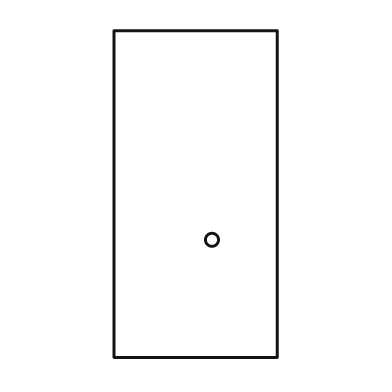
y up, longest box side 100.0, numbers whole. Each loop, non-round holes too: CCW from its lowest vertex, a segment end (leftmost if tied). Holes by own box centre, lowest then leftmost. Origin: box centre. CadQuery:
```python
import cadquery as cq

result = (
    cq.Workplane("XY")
    .moveTo(-25.0, -50.0)
    .lineTo(25.0, -50.0)
    .lineTo(25.0, 50.0)
    .lineTo(-25.0, 50.0)
    .close()
    .moveTo(5.0, -14.0)
    .circle(2.0)
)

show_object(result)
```